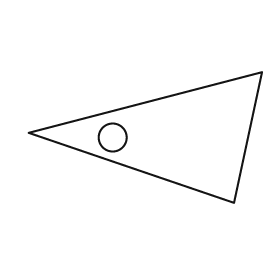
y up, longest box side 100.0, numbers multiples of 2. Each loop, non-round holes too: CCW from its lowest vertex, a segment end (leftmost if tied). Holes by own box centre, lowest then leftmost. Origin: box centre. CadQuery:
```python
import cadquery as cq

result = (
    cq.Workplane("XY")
    .moveTo(38.0, -28.0)
    .lineTo(50.0, 28.0)
    .lineTo(-50.0, 2.0)
    .close()
    .moveTo(-14.0, 0.0)
    .circle(6.0)
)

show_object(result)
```